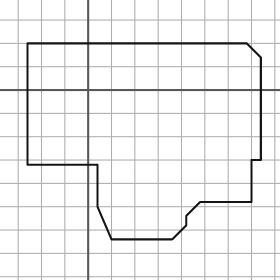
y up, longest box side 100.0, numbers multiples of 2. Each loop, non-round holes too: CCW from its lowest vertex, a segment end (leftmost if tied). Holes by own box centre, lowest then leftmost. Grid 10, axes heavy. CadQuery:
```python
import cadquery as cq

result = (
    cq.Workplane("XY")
    .moveTo(10.0, -64.0)
    .lineTo(36.0, -64.0)
    .lineTo(42.0, -58.0)
    .lineTo(42.0, -54.0)
    .lineTo(48.0, -48.0)
    .lineTo(70.0, -48.0)
    .lineTo(70.0, -30.0)
    .lineTo(74.0, -30.0)
    .lineTo(74.0, 14.0)
    .lineTo(68.0, 20.0)
    .lineTo(-26.0, 20.0)
    .lineTo(-26.0, -32.0)
    .lineTo(4.0, -32.0)
    .lineTo(4.0, -50.0)
    .close()
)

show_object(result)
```